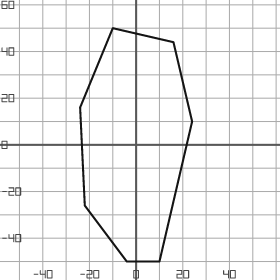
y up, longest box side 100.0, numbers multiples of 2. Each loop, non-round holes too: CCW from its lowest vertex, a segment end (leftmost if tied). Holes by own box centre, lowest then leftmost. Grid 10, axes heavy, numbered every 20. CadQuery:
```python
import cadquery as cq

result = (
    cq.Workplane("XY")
    .moveTo(-4.0, -50.0)
    .lineTo(10.0, -50.0)
    .lineTo(24.0, 10.0)
    .lineTo(16.0, 44.0)
    .lineTo(-10.0, 50.0)
    .lineTo(-24.0, 16.0)
    .lineTo(-22.0, -26.0)
    .close()
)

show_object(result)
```